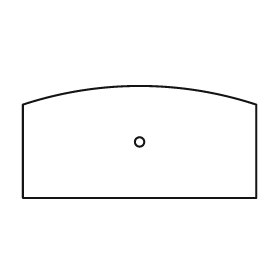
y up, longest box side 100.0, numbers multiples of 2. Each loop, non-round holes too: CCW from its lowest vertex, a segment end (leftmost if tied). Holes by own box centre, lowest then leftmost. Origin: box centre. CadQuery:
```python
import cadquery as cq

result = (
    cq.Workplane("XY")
    .moveTo(-50.0, -24.0)
    .lineTo(50.0, -24.0)
    .lineTo(50.0, 16.0)
    .threePointArc((0.0, 24.0), (-50.0, 16.0))
    .close()
    .moveTo(0.0, 0.0)
    .circle(2.0)
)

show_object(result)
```